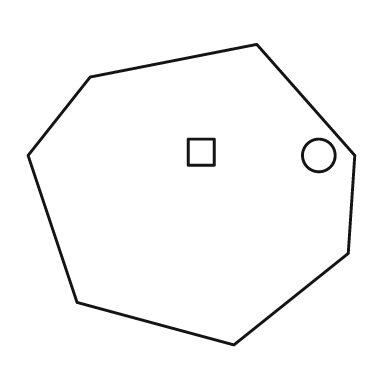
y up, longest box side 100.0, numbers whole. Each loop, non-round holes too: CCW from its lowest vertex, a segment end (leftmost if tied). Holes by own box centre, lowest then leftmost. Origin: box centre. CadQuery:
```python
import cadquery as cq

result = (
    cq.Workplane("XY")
    .moveTo(13.0, -46.0)
    .lineTo(48.0, -18.0)
    .lineTo(50.0, 12.0)
    .lineTo(20.0, 46.0)
    .lineTo(-31.0, 36.0)
    .lineTo(-50.0, 12.0)
    .lineTo(-35.0, -33.0)
    .close()
    .moveTo(39.0, 12.0)
    .circle(5.0)
    .moveTo(-1.0, 9.0)
    .lineTo(7.0, 9.0)
    .lineTo(7.0, 17.0)
    .lineTo(-1.0, 17.0)
    .close()
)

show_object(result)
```